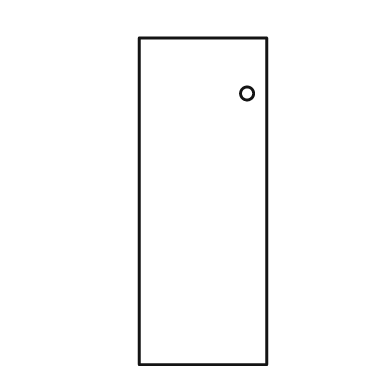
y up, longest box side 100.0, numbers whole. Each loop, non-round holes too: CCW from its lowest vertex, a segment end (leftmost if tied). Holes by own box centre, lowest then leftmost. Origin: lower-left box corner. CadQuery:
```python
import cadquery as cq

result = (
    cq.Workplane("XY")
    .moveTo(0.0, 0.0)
    .lineTo(39.0, 0.0)
    .lineTo(39.0, 100.0)
    .lineTo(0.0, 100.0)
    .close()
    .moveTo(33.0, 83.0)
    .circle(2.0)
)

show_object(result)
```